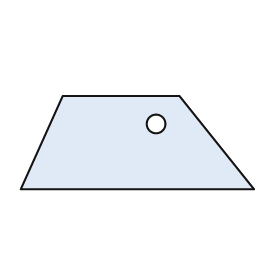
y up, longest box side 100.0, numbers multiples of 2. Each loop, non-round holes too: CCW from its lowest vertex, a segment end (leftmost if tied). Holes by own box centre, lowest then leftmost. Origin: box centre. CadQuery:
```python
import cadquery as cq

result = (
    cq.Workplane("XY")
    .moveTo(-50.0, -20.0)
    .lineTo(50.0, -20.0)
    .lineTo(18.0, 20.0)
    .lineTo(-32.0, 20.0)
    .close()
    .moveTo(8.0, 8.0)
    .circle(4.0)
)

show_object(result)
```